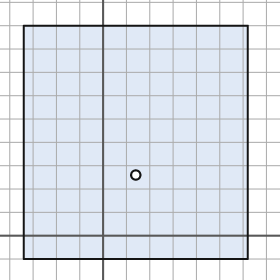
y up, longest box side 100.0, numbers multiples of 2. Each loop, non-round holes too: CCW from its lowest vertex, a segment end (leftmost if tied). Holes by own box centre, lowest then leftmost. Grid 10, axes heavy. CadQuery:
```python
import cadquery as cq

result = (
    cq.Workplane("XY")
    .moveTo(-34.0, -10.0)
    .lineTo(62.0, -10.0)
    .lineTo(62.0, 90.0)
    .lineTo(-34.0, 90.0)
    .close()
    .moveTo(14.0, 26.0)
    .circle(2.0)
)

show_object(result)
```